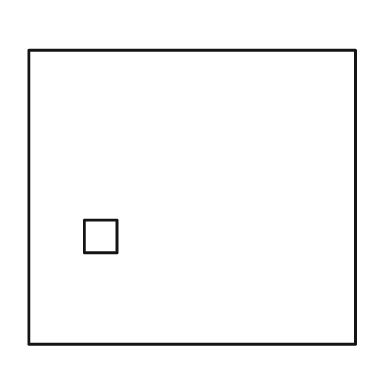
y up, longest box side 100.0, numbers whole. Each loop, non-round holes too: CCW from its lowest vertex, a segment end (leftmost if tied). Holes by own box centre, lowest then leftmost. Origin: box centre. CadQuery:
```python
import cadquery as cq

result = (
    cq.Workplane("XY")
    .moveTo(-50.0, -45.0)
    .lineTo(50.0, -45.0)
    .lineTo(50.0, 45.0)
    .lineTo(-50.0, 45.0)
    .close()
    .moveTo(-33.0, -17.0)
    .lineTo(-23.0, -17.0)
    .lineTo(-23.0, -7.0)
    .lineTo(-33.0, -7.0)
    .close()
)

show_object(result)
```